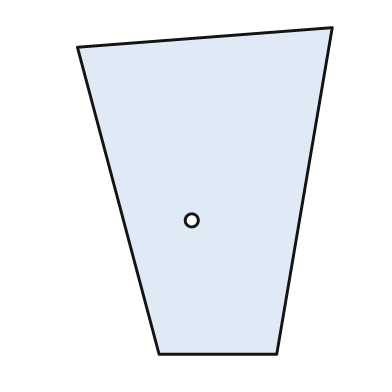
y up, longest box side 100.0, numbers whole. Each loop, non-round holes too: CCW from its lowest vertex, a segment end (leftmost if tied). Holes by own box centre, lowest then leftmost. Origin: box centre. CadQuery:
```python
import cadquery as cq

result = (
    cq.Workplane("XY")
    .moveTo(-14.0, -50.0)
    .lineTo(22.0, -50.0)
    .lineTo(39.0, 50.0)
    .lineTo(-39.0, 44.0)
    .close()
    .moveTo(-4.0, -9.0)
    .circle(2.0)
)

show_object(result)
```